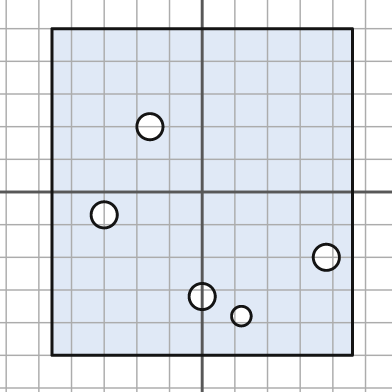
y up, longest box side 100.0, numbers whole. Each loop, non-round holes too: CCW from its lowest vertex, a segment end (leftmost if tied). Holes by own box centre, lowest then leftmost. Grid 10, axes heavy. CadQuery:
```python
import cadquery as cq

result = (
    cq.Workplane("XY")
    .moveTo(-46.0, -50.0)
    .lineTo(46.0, -50.0)
    .lineTo(46.0, 50.0)
    .lineTo(-46.0, 50.0)
    .close()
    .moveTo(12.0, -38.0)
    .circle(3.0)
    .moveTo(0.0, -32.0)
    .circle(4.0)
    .moveTo(38.0, -20.0)
    .circle(4.0)
    .moveTo(-30.0, -7.0)
    .circle(4.0)
    .moveTo(-16.0, 20.0)
    .circle(4.0)
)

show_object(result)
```